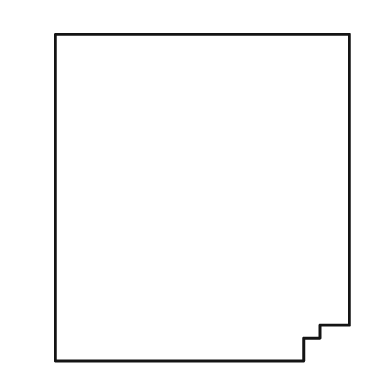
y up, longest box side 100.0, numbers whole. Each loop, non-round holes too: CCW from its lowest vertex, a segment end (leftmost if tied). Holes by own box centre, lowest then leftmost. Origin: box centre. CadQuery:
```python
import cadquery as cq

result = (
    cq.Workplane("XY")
    .moveTo(-45.0, -50.0)
    .lineTo(31.0, -50.0)
    .lineTo(31.0, -43.0)
    .lineTo(36.0, -43.0)
    .lineTo(36.0, -39.0)
    .lineTo(45.0, -39.0)
    .lineTo(45.0, 50.0)
    .lineTo(-45.0, 50.0)
    .close()
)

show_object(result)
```